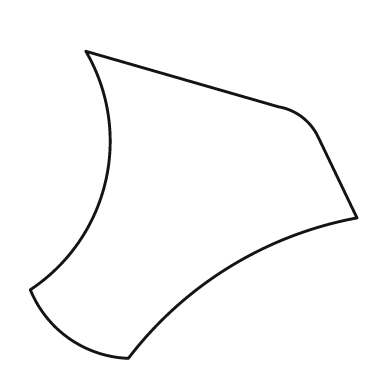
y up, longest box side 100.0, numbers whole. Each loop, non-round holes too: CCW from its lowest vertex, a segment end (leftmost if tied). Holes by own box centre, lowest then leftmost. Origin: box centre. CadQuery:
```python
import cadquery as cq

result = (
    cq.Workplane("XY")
    .moveTo(-20.0, -47.0)
    .threePointArc((11.0, -19.0), (50.0, -4.0))
    .lineTo(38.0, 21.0)
    .threePointArc((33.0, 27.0), (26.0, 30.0))
    .lineTo(-33.0, 47.0)
    .threePointArc((-27.0, 7.0), (-50.0, -26.0))
    .threePointArc((-38.0, -41.0), (-20.0, -47.0))
    .close()
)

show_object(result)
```